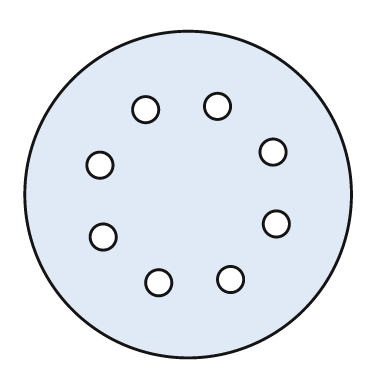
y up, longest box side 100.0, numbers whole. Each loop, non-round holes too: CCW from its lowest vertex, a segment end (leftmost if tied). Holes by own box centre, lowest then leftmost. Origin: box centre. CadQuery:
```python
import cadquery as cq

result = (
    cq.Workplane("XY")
    .moveTo(0.0, 0.0)
    .circle(50.0)
    .moveTo(-9.0, -27.0)
    .circle(4.0)
    .moveTo(13.0, -26.0)
    .circle(4.0)
    .moveTo(-26.0, -13.0)
    .circle(4.0)
    .moveTo(27.0, -9.0)
    .circle(4.0)
    .moveTo(-27.0, 9.0)
    .circle(4.0)
    .moveTo(26.0, 13.0)
    .circle(4.0)
    .moveTo(-13.0, 26.0)
    .circle(4.0)
    .moveTo(9.0, 27.0)
    .circle(4.0)
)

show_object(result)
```